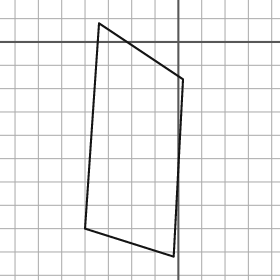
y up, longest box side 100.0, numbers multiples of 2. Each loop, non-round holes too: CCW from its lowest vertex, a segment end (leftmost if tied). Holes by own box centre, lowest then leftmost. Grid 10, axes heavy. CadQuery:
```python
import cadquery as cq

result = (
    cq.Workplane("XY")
    .moveTo(-2.0, -92.0)
    .lineTo(2.0, -16.0)
    .lineTo(-34.0, 8.0)
    .lineTo(-40.0, -80.0)
    .close()
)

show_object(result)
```